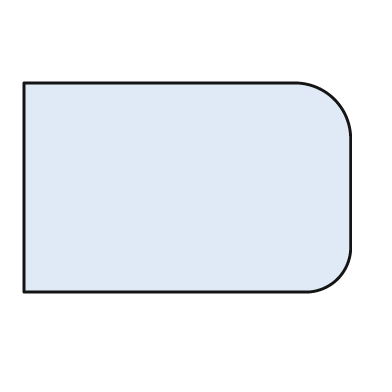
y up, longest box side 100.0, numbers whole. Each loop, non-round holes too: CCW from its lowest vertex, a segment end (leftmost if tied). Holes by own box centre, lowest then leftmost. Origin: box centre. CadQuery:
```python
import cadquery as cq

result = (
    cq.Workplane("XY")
    .moveTo(-50.0, -32.0)
    .lineTo(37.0, -32.0)
    .threePointArc((46.0, -28.0), (50.0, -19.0))
    .lineTo(50.0, 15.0)
    .threePointArc((45.0, 27.0), (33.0, 32.0))
    .lineTo(-50.0, 32.0)
    .close()
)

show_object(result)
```